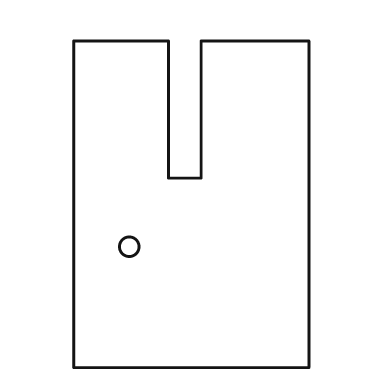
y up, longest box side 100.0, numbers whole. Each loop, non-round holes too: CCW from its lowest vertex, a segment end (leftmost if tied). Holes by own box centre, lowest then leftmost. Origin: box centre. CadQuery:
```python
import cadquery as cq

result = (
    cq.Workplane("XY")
    .moveTo(-36.0, -50.0)
    .lineTo(36.0, -50.0)
    .lineTo(36.0, 50.0)
    .lineTo(3.0, 50.0)
    .lineTo(3.0, 8.0)
    .lineTo(-7.0, 8.0)
    .lineTo(-7.0, 50.0)
    .lineTo(-36.0, 50.0)
    .close()
    .moveTo(-19.0, -13.0)
    .circle(3.0)
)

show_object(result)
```